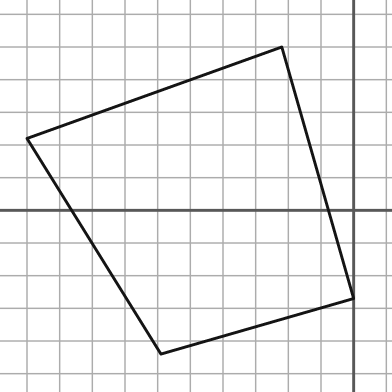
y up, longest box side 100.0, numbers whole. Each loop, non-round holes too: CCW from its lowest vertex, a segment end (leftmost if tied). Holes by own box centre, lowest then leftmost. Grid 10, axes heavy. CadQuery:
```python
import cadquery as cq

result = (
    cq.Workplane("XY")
    .moveTo(-59.0, -44.0)
    .lineTo(0.0, -27.0)
    .lineTo(-22.0, 50.0)
    .lineTo(-100.0, 22.0)
    .close()
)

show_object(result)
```